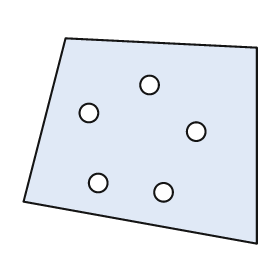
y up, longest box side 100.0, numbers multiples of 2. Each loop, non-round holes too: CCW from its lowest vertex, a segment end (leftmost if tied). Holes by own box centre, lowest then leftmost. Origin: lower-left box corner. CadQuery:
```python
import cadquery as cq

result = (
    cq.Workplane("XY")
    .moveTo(100.0, 0.0)
    .lineTo(100.0, 84.0)
    .lineTo(18.0, 88.0)
    .lineTo(0.0, 18.0)
    .close()
    .moveTo(60.0, 22.0)
    .circle(4.0)
    .moveTo(32.0, 26.0)
    .circle(4.0)
    .moveTo(74.0, 48.0)
    .circle(4.0)
    .moveTo(28.0, 56.0)
    .circle(4.0)
    .moveTo(54.0, 68.0)
    .circle(4.0)
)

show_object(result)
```